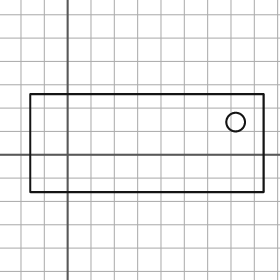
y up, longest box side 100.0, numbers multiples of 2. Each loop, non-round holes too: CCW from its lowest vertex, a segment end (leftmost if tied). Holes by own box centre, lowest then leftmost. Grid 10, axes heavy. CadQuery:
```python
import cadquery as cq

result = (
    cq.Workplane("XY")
    .moveTo(-16.0, -16.0)
    .lineTo(84.0, -16.0)
    .lineTo(84.0, 26.0)
    .lineTo(-16.0, 26.0)
    .close()
    .moveTo(72.0, 14.0)
    .circle(4.0)
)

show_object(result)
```